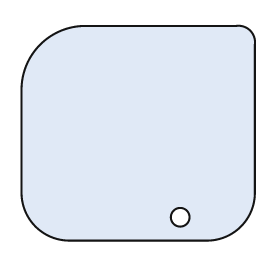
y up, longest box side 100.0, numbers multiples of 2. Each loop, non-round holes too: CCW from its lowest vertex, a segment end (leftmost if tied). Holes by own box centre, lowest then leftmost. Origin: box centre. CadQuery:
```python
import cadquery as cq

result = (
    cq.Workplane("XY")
    .moveTo(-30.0, -46.0)
    .lineTo(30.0, -46.0)
    .threePointArc((44.0, -40.0), (50.0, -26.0))
    .lineTo(50.0, 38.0)
    .threePointArc((48.0, 44.0), (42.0, 46.0))
    .lineTo(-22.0, 46.0)
    .threePointArc((-42.0, 38.0), (-50.0, 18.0))
    .lineTo(-50.0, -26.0)
    .threePointArc((-44.0, -40.0), (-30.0, -46.0))
    .close()
    .moveTo(18.0, -36.0)
    .circle(4.0)
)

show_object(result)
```